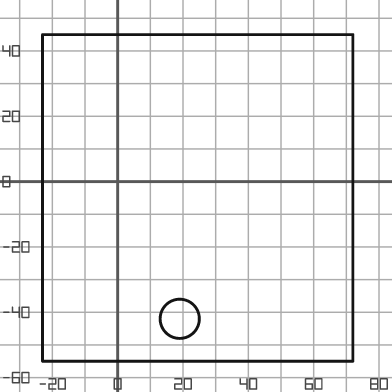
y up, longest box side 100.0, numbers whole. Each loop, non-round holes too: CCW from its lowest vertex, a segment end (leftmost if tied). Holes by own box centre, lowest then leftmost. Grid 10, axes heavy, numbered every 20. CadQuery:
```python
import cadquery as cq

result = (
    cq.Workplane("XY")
    .moveTo(-23.0, -55.0)
    .lineTo(72.0, -55.0)
    .lineTo(72.0, 45.0)
    .lineTo(-23.0, 45.0)
    .close()
    .moveTo(19.0, -42.0)
    .circle(6.0)
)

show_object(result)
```